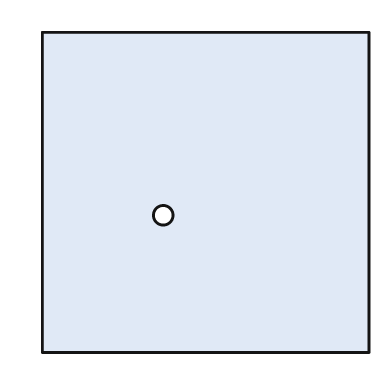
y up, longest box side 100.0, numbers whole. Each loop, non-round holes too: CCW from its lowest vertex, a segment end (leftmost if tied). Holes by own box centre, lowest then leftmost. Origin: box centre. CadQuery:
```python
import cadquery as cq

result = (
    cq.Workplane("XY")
    .moveTo(-50.0, -49.0)
    .lineTo(50.0, -49.0)
    .lineTo(50.0, 49.0)
    .lineTo(-50.0, 49.0)
    .close()
    .moveTo(-13.0, -7.0)
    .circle(3.0)
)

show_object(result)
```